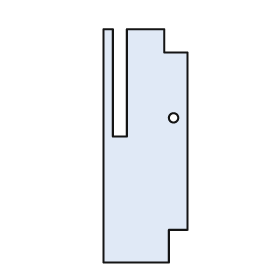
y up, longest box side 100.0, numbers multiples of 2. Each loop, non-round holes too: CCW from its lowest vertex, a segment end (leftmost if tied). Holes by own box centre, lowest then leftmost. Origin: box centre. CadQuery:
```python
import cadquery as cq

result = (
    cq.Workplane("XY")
    .moveTo(-18.0, -50.0)
    .lineTo(10.0, -50.0)
    .lineTo(10.0, -36.0)
    .lineTo(18.0, -36.0)
    .lineTo(18.0, 40.0)
    .lineTo(8.0, 40.0)
    .lineTo(8.0, 50.0)
    .lineTo(-8.0, 50.0)
    .lineTo(-8.0, 4.0)
    .lineTo(-14.0, 4.0)
    .lineTo(-14.0, 50.0)
    .lineTo(-18.0, 50.0)
    .close()
    .moveTo(12.0, 12.0)
    .circle(2.0)
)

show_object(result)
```